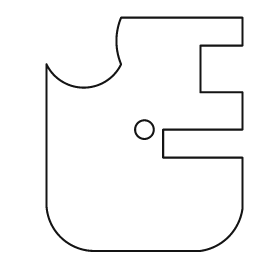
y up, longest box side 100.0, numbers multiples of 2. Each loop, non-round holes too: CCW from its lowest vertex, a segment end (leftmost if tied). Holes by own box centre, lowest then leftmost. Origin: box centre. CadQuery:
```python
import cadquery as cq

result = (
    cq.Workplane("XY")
    .moveTo(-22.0, -50.0)
    .lineTo(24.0, -50.0)
    .threePointArc((36.0, -44.0), (42.0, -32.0))
    .lineTo(42.0, -10.0)
    .lineTo(8.0, -10.0)
    .lineTo(8.0, 2.0)
    .lineTo(42.0, 2.0)
    .lineTo(42.0, 18.0)
    .lineTo(24.0, 18.0)
    .lineTo(24.0, 38.0)
    .lineTo(42.0, 38.0)
    .lineTo(42.0, 50.0)
    .lineTo(-10.0, 50.0)
    .threePointArc((-12.0, 40.0), (-10.0, 30.0))
    .threePointArc((-26.0, 20.0), (-42.0, 30.0))
    .lineTo(-42.0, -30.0)
    .threePointArc((-36.0, -44.0), (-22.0, -50.0))
    .close()
    .moveTo(0.0, 2.0)
    .circle(4.0)
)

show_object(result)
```